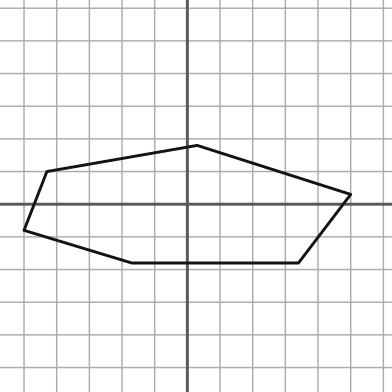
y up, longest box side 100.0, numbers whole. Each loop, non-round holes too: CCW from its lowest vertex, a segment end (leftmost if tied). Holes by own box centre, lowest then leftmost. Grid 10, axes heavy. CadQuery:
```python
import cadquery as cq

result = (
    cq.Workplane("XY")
    .moveTo(-17.0, -18.0)
    .lineTo(34.0, -18.0)
    .lineTo(50.0, 3.0)
    .lineTo(3.0, 18.0)
    .lineTo(-43.0, 10.0)
    .lineTo(-50.0, -8.0)
    .close()
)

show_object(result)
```